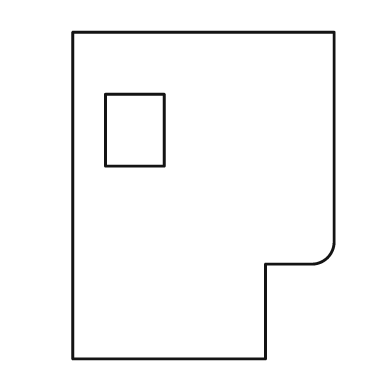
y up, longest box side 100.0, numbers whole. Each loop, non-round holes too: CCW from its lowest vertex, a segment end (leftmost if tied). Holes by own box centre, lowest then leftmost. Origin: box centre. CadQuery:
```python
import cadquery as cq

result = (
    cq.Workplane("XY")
    .moveTo(-40.0, -50.0)
    .lineTo(19.0, -50.0)
    .lineTo(19.0, -21.0)
    .lineTo(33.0, -21.0)
    .threePointArc((38.0, -19.0), (40.0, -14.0))
    .lineTo(40.0, 50.0)
    .lineTo(-40.0, 50.0)
    .close()
    .moveTo(-30.0, 9.0)
    .lineTo(-12.0, 9.0)
    .lineTo(-12.0, 31.0)
    .lineTo(-30.0, 31.0)
    .close()
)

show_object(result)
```